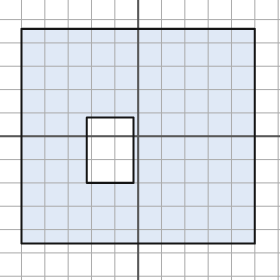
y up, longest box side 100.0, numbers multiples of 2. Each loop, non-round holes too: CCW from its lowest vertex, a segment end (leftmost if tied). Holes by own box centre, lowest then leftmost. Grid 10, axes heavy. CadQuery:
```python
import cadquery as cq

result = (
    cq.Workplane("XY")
    .moveTo(-50.0, -46.0)
    .lineTo(50.0, -46.0)
    .lineTo(50.0, 46.0)
    .lineTo(-50.0, 46.0)
    .close()
    .moveTo(-22.0, -20.0)
    .lineTo(-2.0, -20.0)
    .lineTo(-2.0, 8.0)
    .lineTo(-22.0, 8.0)
    .close()
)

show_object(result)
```